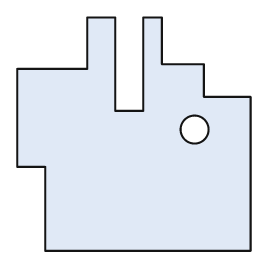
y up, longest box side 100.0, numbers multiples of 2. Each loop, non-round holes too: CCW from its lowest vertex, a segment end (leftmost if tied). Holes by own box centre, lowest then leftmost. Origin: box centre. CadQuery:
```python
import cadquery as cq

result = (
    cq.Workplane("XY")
    .moveTo(-38.0, -50.0)
    .lineTo(50.0, -50.0)
    .lineTo(50.0, 16.0)
    .lineTo(30.0, 16.0)
    .lineTo(30.0, 30.0)
    .lineTo(12.0, 30.0)
    .lineTo(12.0, 50.0)
    .lineTo(4.0, 50.0)
    .lineTo(4.0, 10.0)
    .lineTo(-8.0, 10.0)
    .lineTo(-8.0, 50.0)
    .lineTo(-20.0, 50.0)
    .lineTo(-20.0, 28.0)
    .lineTo(-50.0, 28.0)
    .lineTo(-50.0, -14.0)
    .lineTo(-38.0, -14.0)
    .close()
    .moveTo(26.0, 2.0)
    .circle(6.0)
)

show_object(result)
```